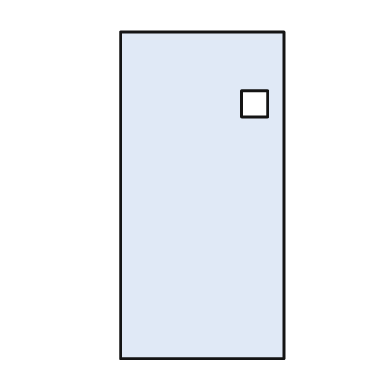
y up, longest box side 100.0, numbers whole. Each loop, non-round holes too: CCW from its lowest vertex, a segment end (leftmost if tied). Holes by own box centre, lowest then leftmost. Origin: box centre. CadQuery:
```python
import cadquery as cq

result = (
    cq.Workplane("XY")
    .moveTo(-25.0, -50.0)
    .lineTo(25.0, -50.0)
    .lineTo(25.0, 50.0)
    .lineTo(-25.0, 50.0)
    .close()
    .moveTo(12.0, 24.0)
    .lineTo(20.0, 24.0)
    .lineTo(20.0, 32.0)
    .lineTo(12.0, 32.0)
    .close()
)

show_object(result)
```